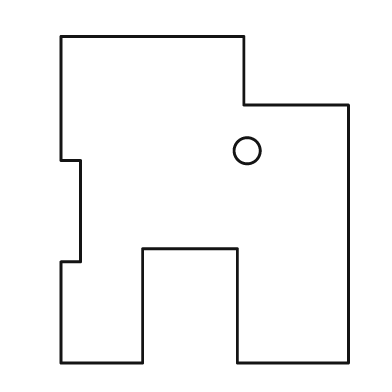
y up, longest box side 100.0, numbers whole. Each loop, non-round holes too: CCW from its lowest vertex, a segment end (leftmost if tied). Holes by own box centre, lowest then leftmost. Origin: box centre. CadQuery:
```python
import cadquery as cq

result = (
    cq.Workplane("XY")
    .moveTo(-44.0, -50.0)
    .lineTo(-19.0, -50.0)
    .lineTo(-19.0, -15.0)
    .lineTo(10.0, -15.0)
    .lineTo(10.0, -50.0)
    .lineTo(44.0, -50.0)
    .lineTo(44.0, 29.0)
    .lineTo(12.0, 29.0)
    .lineTo(12.0, 50.0)
    .lineTo(-44.0, 50.0)
    .lineTo(-44.0, 12.0)
    .lineTo(-38.0, 12.0)
    .lineTo(-38.0, -19.0)
    .lineTo(-44.0, -19.0)
    .close()
    .moveTo(13.0, 15.0)
    .circle(4.0)
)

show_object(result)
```